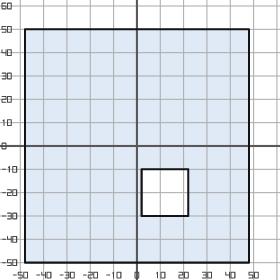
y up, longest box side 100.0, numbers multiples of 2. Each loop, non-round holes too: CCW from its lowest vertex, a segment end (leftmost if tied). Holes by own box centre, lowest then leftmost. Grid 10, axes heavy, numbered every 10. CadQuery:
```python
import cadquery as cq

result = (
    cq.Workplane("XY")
    .moveTo(-48.0, -50.0)
    .lineTo(48.0, -50.0)
    .lineTo(48.0, 50.0)
    .lineTo(-48.0, 50.0)
    .close()
    .moveTo(2.0, -30.0)
    .lineTo(22.0, -30.0)
    .lineTo(22.0, -10.0)
    .lineTo(2.0, -10.0)
    .close()
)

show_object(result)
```